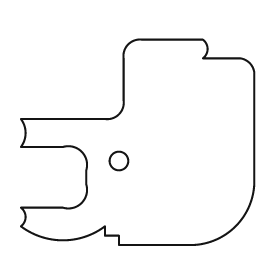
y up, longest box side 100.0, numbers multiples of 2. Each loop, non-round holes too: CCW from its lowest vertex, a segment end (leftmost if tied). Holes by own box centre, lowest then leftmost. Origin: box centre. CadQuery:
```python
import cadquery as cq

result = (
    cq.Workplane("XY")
    .moveTo(-8.0, -44.0)
    .lineTo(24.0, -44.0)
    .threePointArc((42.0, -36.0), (50.0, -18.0))
    .lineTo(50.0, 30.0)
    .threePointArc((48.0, 34.0), (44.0, 36.0))
    .lineTo(28.0, 36.0)
    .threePointArc((30.0, 40.0), (28.0, 44.0))
    .lineTo(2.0, 44.0)
    .threePointArc((-4.0, 42.0), (-6.0, 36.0))
    .lineTo(-6.0, 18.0)
    .threePointArc((-8.0, 12.0), (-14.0, 10.0))
    .lineTo(-50.0, 10.0)
    .threePointArc((-48.0, 4.0), (-50.0, -2.0))
    .lineTo(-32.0, -2.0)
    .threePointArc((-24.0, -4.0), (-22.0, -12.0))
    .lineTo(-22.0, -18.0)
    .threePointArc((-24.0, -26.0), (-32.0, -28.0))
    .lineTo(-50.0, -28.0)
    .threePointArc((-48.0, -32.0), (-50.0, -36.0))
    .threePointArc((-32.0, -42.0), (-14.0, -36.0))
    .lineTo(-14.0, -40.0)
    .lineTo(-8.0, -40.0)
    .close()
    .moveTo(-8.0, -8.0)
    .circle(4.0)
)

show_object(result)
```